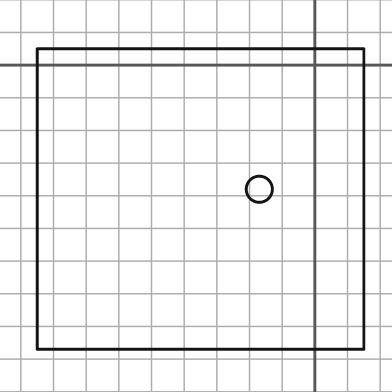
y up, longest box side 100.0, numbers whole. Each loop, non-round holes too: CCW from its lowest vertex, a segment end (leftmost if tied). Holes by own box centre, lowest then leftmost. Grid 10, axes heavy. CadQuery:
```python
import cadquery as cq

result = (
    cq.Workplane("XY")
    .moveTo(-85.0, -87.0)
    .lineTo(15.0, -87.0)
    .lineTo(15.0, 5.0)
    .lineTo(-85.0, 5.0)
    .close()
    .moveTo(-17.0, -38.0)
    .circle(4.0)
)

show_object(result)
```